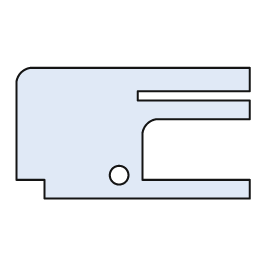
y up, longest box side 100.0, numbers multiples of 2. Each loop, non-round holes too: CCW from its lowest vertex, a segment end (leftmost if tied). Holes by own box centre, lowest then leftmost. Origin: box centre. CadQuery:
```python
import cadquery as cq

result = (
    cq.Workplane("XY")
    .moveTo(-38.0, -28.0)
    .lineTo(50.0, -28.0)
    .lineTo(50.0, -20.0)
    .lineTo(4.0, -20.0)
    .lineTo(4.0, 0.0)
    .threePointArc((6.0, 4.0), (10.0, 6.0))
    .lineTo(50.0, 6.0)
    .lineTo(50.0, 14.0)
    .lineTo(2.0, 14.0)
    .lineTo(2.0, 18.0)
    .lineTo(50.0, 18.0)
    .lineTo(50.0, 28.0)
    .lineTo(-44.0, 28.0)
    .threePointArc((-48.0, 26.0), (-50.0, 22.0))
    .lineTo(-50.0, -20.0)
    .lineTo(-38.0, -20.0)
    .close()
    .moveTo(-6.0, -18.0)
    .circle(4.0)
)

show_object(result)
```